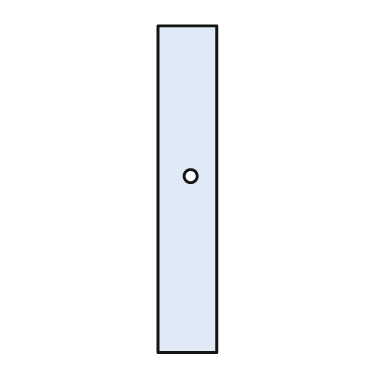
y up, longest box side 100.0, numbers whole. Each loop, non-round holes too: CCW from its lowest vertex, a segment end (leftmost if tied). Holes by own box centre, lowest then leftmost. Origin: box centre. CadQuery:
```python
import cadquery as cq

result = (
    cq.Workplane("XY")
    .moveTo(-9.0, -50.0)
    .lineTo(9.0, -50.0)
    .lineTo(9.0, 50.0)
    .lineTo(-9.0, 50.0)
    .close()
    .moveTo(1.0, 4.0)
    .circle(2.0)
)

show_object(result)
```